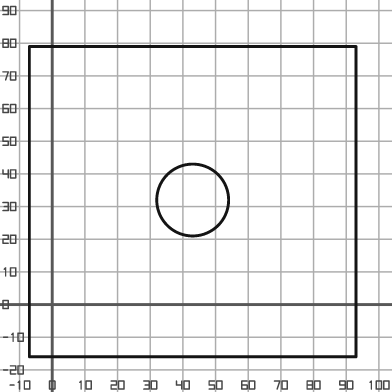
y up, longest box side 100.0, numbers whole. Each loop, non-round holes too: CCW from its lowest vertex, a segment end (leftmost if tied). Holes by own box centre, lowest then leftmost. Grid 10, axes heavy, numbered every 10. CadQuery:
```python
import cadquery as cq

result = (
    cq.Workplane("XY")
    .moveTo(-7.0, -16.0)
    .lineTo(93.0, -16.0)
    .lineTo(93.0, 79.0)
    .lineTo(-7.0, 79.0)
    .close()
    .moveTo(43.0, 32.0)
    .circle(11.0)
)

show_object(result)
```